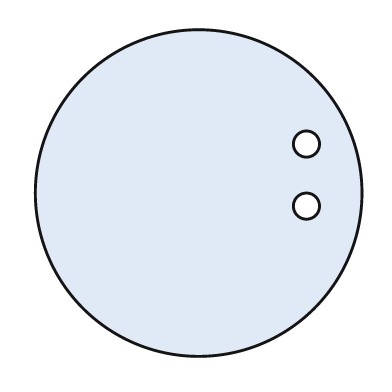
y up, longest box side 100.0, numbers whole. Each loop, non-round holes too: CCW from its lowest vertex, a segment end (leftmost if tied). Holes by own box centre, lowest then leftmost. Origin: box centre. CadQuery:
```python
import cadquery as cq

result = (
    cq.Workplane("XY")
    .moveTo(0.0, 0.0)
    .circle(50.0)
    .moveTo(33.0, -4.0)
    .circle(4.0)
    .moveTo(33.0, 15.0)
    .circle(4.0)
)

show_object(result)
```